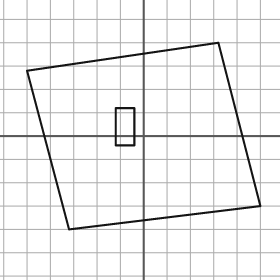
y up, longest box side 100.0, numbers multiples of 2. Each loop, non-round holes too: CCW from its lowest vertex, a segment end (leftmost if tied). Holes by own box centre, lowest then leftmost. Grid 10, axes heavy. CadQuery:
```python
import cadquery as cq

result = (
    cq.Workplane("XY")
    .moveTo(-32.0, -40.0)
    .lineTo(50.0, -30.0)
    .lineTo(32.0, 40.0)
    .lineTo(-50.0, 28.0)
    .close()
    .moveTo(-12.0, -4.0)
    .lineTo(-4.0, -4.0)
    .lineTo(-4.0, 12.0)
    .lineTo(-12.0, 12.0)
    .close()
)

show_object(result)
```